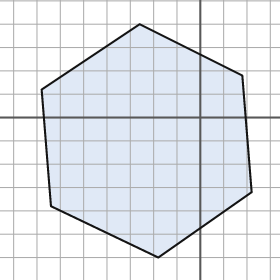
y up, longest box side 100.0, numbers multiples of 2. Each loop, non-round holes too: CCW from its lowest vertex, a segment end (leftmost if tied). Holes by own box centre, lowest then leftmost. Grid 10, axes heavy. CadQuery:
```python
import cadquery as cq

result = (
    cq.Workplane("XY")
    .moveTo(-18.0, -60.0)
    .lineTo(22.0, -32.0)
    .lineTo(18.0, 18.0)
    .lineTo(-26.0, 40.0)
    .lineTo(-68.0, 12.0)
    .lineTo(-64.0, -38.0)
    .close()
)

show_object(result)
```